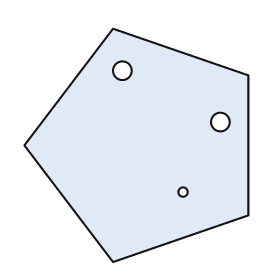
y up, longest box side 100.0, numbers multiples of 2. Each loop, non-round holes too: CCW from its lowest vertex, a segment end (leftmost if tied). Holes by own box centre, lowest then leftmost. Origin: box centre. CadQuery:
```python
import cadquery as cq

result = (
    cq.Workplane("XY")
    .moveTo(-10.0, -50.0)
    .lineTo(48.0, -30.0)
    .lineTo(48.0, 30.0)
    .lineTo(-10.0, 50.0)
    .lineTo(-48.0, 0.0)
    .close()
    .moveTo(20.0, -20.0)
    .circle(2.0)
    .moveTo(36.0, 10.0)
    .circle(4.0)
    .moveTo(-6.0, 32.0)
    .circle(4.0)
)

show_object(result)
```